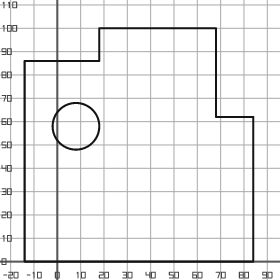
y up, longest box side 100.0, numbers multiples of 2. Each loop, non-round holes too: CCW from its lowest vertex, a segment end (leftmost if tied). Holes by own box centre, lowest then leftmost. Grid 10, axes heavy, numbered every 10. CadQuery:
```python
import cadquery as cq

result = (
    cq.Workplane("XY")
    .moveTo(-14.0, 0.0)
    .lineTo(84.0, 0.0)
    .lineTo(84.0, 62.0)
    .lineTo(68.0, 62.0)
    .lineTo(68.0, 100.0)
    .lineTo(18.0, 100.0)
    .lineTo(18.0, 86.0)
    .lineTo(-14.0, 86.0)
    .close()
    .moveTo(8.0, 58.0)
    .circle(10.0)
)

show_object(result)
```